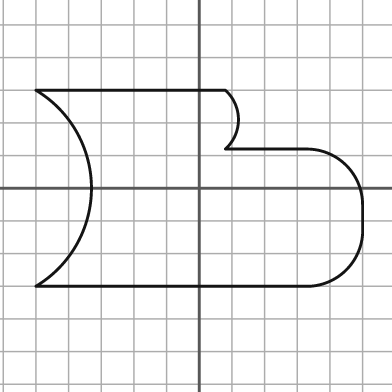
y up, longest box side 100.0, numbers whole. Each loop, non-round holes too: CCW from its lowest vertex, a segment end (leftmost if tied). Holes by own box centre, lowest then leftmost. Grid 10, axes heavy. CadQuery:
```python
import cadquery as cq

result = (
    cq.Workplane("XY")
    .moveTo(-50.0, -30.0)
    .lineTo(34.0, -30.0)
    .threePointArc((45.0, -25.0), (50.0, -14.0))
    .lineTo(50.0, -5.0)
    .threePointArc((45.0, 7.0), (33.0, 12.0))
    .lineTo(8.0, 12.0)
    .threePointArc((12.0, 21.0), (8.0, 30.0))
    .lineTo(-50.0, 30.0)
    .threePointArc((-33.0, 0.0), (-50.0, -30.0))
    .close()
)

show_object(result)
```